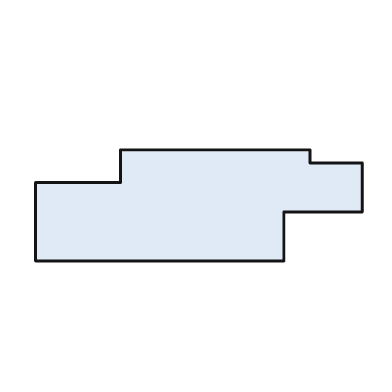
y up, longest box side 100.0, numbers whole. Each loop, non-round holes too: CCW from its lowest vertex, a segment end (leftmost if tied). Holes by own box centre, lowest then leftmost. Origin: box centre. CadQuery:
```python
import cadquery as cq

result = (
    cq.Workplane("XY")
    .moveTo(-50.0, -17.0)
    .lineTo(26.0, -17.0)
    .lineTo(26.0, -2.0)
    .lineTo(50.0, -2.0)
    .lineTo(50.0, 13.0)
    .lineTo(34.0, 13.0)
    .lineTo(34.0, 17.0)
    .lineTo(-24.0, 17.0)
    .lineTo(-24.0, 7.0)
    .lineTo(-50.0, 7.0)
    .close()
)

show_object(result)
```